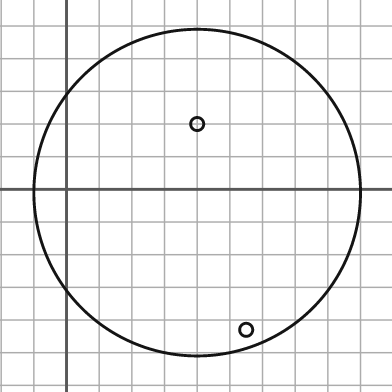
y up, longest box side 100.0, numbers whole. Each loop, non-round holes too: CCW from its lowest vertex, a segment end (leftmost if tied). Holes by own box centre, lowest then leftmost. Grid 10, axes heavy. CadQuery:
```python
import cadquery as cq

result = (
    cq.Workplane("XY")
    .moveTo(40.0, -1.0)
    .circle(50.0)
    .moveTo(55.0, -43.0)
    .circle(2.0)
    .moveTo(40.0, 20.0)
    .circle(2.0)
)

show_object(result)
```